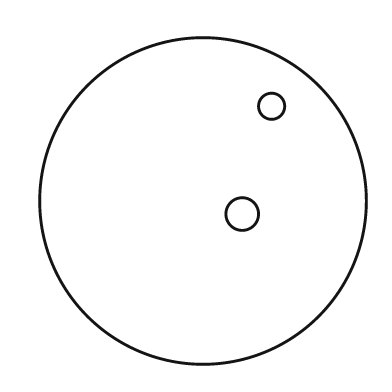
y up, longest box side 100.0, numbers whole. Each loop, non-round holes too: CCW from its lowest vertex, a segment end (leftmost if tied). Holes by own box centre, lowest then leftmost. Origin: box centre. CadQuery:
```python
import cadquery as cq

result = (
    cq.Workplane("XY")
    .moveTo(0.0, 0.0)
    .circle(50.0)
    .moveTo(12.0, -4.0)
    .circle(5.0)
    .moveTo(21.0, 29.0)
    .circle(4.0)
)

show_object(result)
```